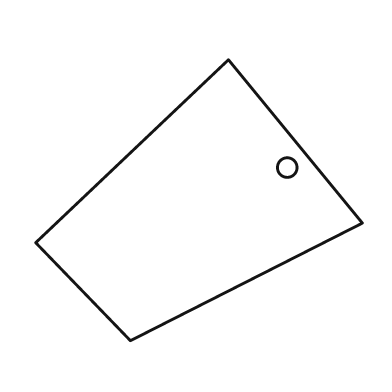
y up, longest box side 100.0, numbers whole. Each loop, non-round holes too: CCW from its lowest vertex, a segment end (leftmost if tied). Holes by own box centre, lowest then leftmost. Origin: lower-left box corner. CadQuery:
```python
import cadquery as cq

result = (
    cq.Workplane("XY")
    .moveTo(29.0, 0.0)
    .lineTo(100.0, 36.0)
    .lineTo(59.0, 86.0)
    .lineTo(0.0, 30.0)
    .close()
    .moveTo(77.0, 53.0)
    .circle(3.0)
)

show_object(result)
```